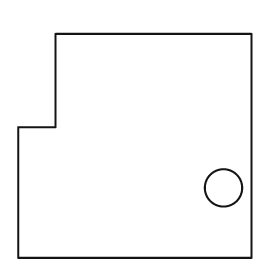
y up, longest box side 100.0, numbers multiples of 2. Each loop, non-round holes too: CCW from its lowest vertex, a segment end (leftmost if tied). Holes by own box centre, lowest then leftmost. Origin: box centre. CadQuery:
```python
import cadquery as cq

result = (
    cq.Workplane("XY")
    .moveTo(-50.0, -48.0)
    .lineTo(50.0, -48.0)
    .lineTo(50.0, 48.0)
    .lineTo(-34.0, 48.0)
    .lineTo(-34.0, 8.0)
    .lineTo(-50.0, 8.0)
    .close()
    .moveTo(38.0, -18.0)
    .circle(8.0)
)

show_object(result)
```